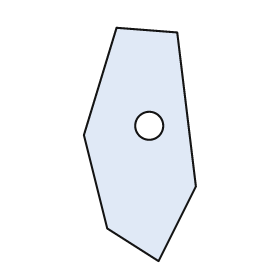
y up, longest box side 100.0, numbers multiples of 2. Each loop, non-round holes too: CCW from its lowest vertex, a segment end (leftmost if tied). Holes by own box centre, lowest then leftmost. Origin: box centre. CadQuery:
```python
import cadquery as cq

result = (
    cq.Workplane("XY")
    .moveTo(8.0, -50.0)
    .lineTo(24.0, -18.0)
    .lineTo(16.0, 48.0)
    .lineTo(-10.0, 50.0)
    .lineTo(-24.0, 4.0)
    .lineTo(-14.0, -36.0)
    .close()
    .moveTo(4.0, 8.0)
    .circle(6.0)
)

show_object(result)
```